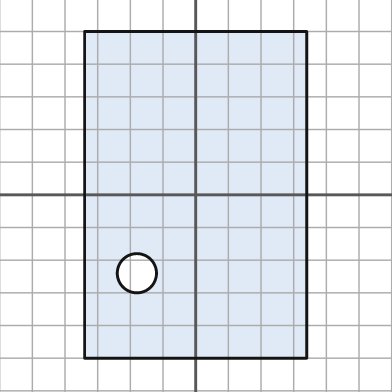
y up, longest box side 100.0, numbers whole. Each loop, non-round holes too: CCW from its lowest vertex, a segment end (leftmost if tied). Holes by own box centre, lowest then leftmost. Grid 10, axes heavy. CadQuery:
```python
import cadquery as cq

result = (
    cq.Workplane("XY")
    .moveTo(-34.0, -50.0)
    .lineTo(34.0, -50.0)
    .lineTo(34.0, 50.0)
    .lineTo(-34.0, 50.0)
    .close()
    .moveTo(-18.0, -24.0)
    .circle(6.0)
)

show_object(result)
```